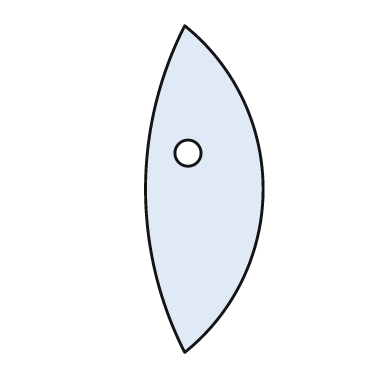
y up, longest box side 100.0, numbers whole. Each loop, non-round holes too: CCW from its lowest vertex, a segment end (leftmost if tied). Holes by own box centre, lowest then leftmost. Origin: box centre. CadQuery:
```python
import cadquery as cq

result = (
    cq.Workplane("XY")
    .moveTo(-6.0, -50.0)
    .threePointArc((18.0, 0.0), (-6.0, 50.0))
    .threePointArc((-18.0, 0.0), (-6.0, -50.0))
    .close()
    .moveTo(-5.0, 11.0)
    .circle(4.0)
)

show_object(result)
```